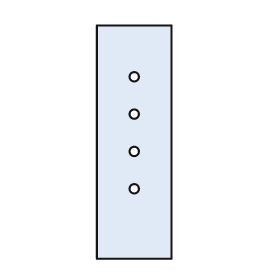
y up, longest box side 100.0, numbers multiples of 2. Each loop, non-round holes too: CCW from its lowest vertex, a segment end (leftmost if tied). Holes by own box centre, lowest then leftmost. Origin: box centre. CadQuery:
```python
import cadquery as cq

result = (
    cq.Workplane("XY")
    .moveTo(-16.0, -50.0)
    .lineTo(16.0, -50.0)
    .lineTo(16.0, 50.0)
    .lineTo(-16.0, 50.0)
    .close()
    .moveTo(0.0, -20.0)
    .circle(2.0)
    .moveTo(0.0, -4.0)
    .circle(2.0)
    .moveTo(0.0, 12.0)
    .circle(2.0)
    .moveTo(0.0, 28.0)
    .circle(2.0)
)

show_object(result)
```